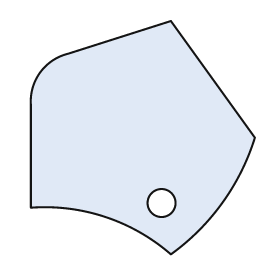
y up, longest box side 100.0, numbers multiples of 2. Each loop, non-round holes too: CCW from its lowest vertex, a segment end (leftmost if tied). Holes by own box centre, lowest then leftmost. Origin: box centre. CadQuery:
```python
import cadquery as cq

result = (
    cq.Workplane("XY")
    .moveTo(12.0, -50.0)
    .threePointArc((34.0, -28.0), (48.0, 0.0))
    .lineTo(12.0, 50.0)
    .lineTo(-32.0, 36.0)
    .threePointArc((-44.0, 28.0), (-48.0, 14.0))
    .lineTo(-48.0, -30.0)
    .threePointArc((-16.0, -34.0), (12.0, -50.0))
    .close()
    .moveTo(8.0, -28.0)
    .circle(6.0)
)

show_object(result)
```